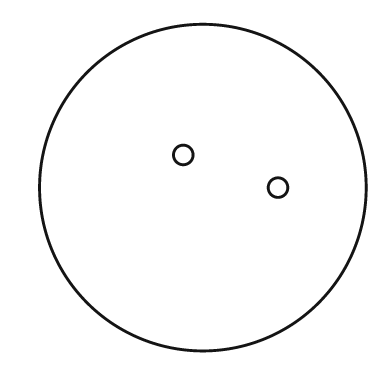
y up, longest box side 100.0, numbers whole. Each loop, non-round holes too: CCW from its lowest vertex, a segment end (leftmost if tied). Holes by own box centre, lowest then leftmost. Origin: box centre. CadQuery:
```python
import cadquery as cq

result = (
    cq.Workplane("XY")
    .moveTo(0.0, 0.0)
    .circle(50.0)
    .moveTo(23.0, 0.0)
    .circle(3.0)
    .moveTo(-6.0, 10.0)
    .circle(3.0)
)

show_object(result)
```